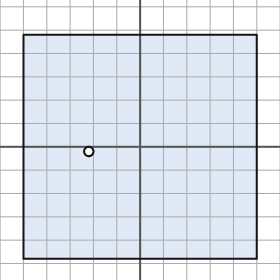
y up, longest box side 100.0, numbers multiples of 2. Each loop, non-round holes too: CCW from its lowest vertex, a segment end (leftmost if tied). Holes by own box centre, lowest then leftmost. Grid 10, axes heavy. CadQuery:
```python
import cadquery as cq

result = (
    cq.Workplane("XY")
    .moveTo(-50.0, -48.0)
    .lineTo(50.0, -48.0)
    .lineTo(50.0, 48.0)
    .lineTo(-50.0, 48.0)
    .close()
    .moveTo(-22.0, -2.0)
    .circle(2.0)
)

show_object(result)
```